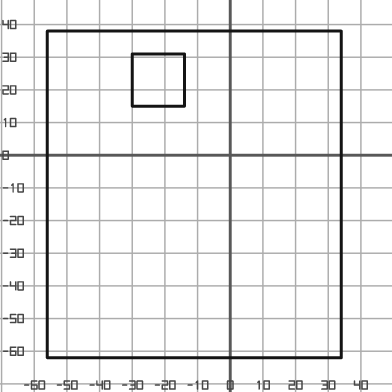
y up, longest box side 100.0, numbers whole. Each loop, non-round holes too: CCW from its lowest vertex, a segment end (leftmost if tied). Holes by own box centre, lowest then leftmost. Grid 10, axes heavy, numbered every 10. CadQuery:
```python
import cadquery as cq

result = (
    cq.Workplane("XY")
    .moveTo(-56.0, -62.0)
    .lineTo(34.0, -62.0)
    .lineTo(34.0, 38.0)
    .lineTo(-56.0, 38.0)
    .close()
    .moveTo(-30.0, 15.0)
    .lineTo(-14.0, 15.0)
    .lineTo(-14.0, 31.0)
    .lineTo(-30.0, 31.0)
    .close()
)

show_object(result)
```